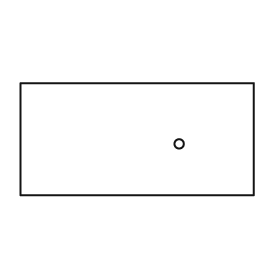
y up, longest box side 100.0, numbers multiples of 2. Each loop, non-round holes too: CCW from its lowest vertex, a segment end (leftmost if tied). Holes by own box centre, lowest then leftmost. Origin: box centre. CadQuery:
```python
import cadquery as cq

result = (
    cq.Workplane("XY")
    .moveTo(-50.0, -24.0)
    .lineTo(50.0, -24.0)
    .lineTo(50.0, 24.0)
    .lineTo(-50.0, 24.0)
    .close()
    .moveTo(18.0, -2.0)
    .circle(2.0)
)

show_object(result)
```